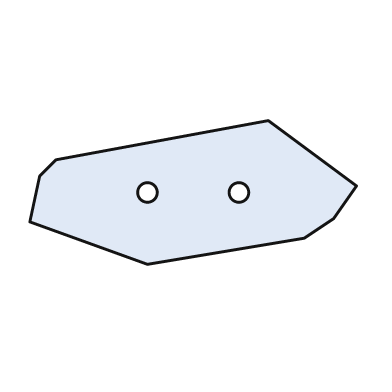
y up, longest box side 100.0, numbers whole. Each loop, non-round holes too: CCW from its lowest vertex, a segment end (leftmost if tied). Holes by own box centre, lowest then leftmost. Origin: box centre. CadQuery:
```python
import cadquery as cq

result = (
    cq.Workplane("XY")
    .moveTo(-14.0, -22.0)
    .lineTo(34.0, -14.0)
    .lineTo(43.0, -8.0)
    .lineTo(50.0, 2.0)
    .lineTo(23.0, 22.0)
    .lineTo(-42.0, 10.0)
    .lineTo(-47.0, 5.0)
    .lineTo(-50.0, -9.0)
    .close()
    .moveTo(-14.0, 0.0)
    .circle(3.0)
    .moveTo(14.0, 0.0)
    .circle(3.0)
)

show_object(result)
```